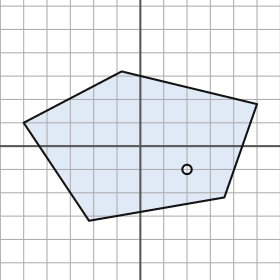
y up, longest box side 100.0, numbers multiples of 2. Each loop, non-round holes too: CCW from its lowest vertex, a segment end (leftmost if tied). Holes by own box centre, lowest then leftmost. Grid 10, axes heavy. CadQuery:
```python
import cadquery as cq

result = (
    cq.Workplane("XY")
    .moveTo(-22.0, -32.0)
    .lineTo(36.0, -22.0)
    .lineTo(50.0, 18.0)
    .lineTo(-8.0, 32.0)
    .lineTo(-50.0, 10.0)
    .close()
    .moveTo(20.0, -10.0)
    .circle(2.0)
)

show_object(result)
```